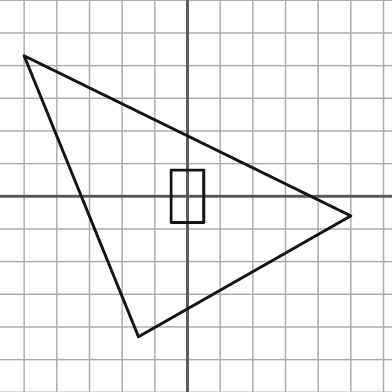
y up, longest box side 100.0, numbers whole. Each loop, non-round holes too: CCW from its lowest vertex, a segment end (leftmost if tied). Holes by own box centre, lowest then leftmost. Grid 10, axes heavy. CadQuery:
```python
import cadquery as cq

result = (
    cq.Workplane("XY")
    .moveTo(-15.0, -43.0)
    .lineTo(50.0, -6.0)
    .lineTo(-50.0, 43.0)
    .close()
    .moveTo(-5.0, -8.0)
    .lineTo(5.0, -8.0)
    .lineTo(5.0, 8.0)
    .lineTo(-5.0, 8.0)
    .close()
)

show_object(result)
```